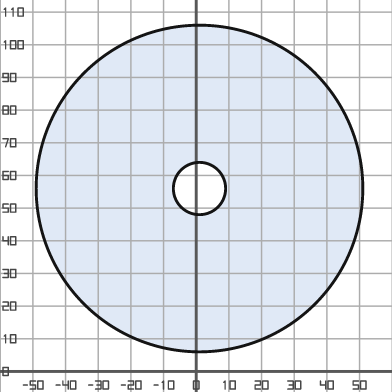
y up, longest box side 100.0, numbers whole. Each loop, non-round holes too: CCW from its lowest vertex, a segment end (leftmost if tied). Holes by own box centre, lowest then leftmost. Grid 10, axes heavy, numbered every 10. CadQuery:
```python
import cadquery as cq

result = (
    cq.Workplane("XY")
    .moveTo(1.0, 56.0)
    .circle(50.0)
    .moveTo(1.0, 56.0)
    .circle(8.0)
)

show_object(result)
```